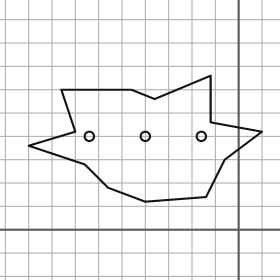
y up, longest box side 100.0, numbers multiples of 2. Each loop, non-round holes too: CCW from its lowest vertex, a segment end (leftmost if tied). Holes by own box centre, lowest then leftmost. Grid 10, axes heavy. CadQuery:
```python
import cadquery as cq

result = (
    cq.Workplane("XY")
    .moveTo(-40.0, 12.0)
    .lineTo(-14.0, 14.0)
    .lineTo(-6.0, 30.0)
    .lineTo(10.0, 42.0)
    .lineTo(-12.0, 46.0)
    .lineTo(-12.0, 66.0)
    .lineTo(-36.0, 56.0)
    .lineTo(-46.0, 60.0)
    .lineTo(-76.0, 60.0)
    .lineTo(-70.0, 42.0)
    .lineTo(-90.0, 36.0)
    .lineTo(-66.0, 28.0)
    .lineTo(-56.0, 18.0)
    .close()
    .moveTo(-64.0, 40.0)
    .circle(2.0)
    .moveTo(-40.0, 40.0)
    .circle(2.0)
    .moveTo(-16.0, 40.0)
    .circle(2.0)
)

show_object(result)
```